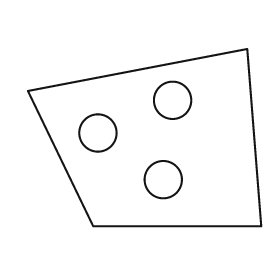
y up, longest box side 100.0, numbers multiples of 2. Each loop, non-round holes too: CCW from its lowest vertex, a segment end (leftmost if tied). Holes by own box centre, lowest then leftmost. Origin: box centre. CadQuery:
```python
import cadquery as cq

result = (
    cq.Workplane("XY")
    .moveTo(-22.0, -38.0)
    .lineTo(50.0, -38.0)
    .lineTo(44.0, 38.0)
    .lineTo(-50.0, 20.0)
    .close()
    .moveTo(8.0, -18.0)
    .circle(8.0)
    .moveTo(-20.0, 2.0)
    .circle(8.0)
    .moveTo(12.0, 16.0)
    .circle(8.0)
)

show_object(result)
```